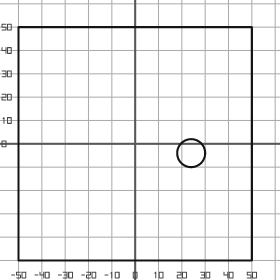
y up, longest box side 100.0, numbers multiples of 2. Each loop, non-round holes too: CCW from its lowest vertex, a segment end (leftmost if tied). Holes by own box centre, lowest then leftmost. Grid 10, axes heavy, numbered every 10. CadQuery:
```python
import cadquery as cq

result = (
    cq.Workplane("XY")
    .moveTo(-50.0, -50.0)
    .lineTo(50.0, -50.0)
    .lineTo(50.0, 50.0)
    .lineTo(-50.0, 50.0)
    .close()
    .moveTo(24.0, -4.0)
    .circle(6.0)
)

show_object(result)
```